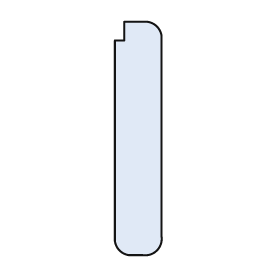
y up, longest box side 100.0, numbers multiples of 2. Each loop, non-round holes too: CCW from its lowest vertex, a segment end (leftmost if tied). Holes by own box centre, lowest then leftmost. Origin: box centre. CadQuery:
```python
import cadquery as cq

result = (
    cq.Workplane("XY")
    .moveTo(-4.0, -50.0)
    .lineTo(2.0, -50.0)
    .threePointArc((8.0, -48.0), (10.0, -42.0))
    .lineTo(10.0, 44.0)
    .threePointArc((8.0, 48.0), (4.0, 50.0))
    .lineTo(-6.0, 50.0)
    .lineTo(-6.0, 42.0)
    .lineTo(-10.0, 42.0)
    .lineTo(-10.0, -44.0)
    .threePointArc((-8.0, -48.0), (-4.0, -50.0))
    .close()
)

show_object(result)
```